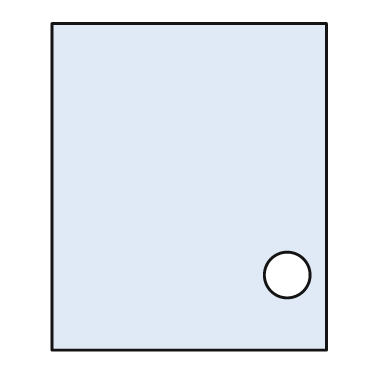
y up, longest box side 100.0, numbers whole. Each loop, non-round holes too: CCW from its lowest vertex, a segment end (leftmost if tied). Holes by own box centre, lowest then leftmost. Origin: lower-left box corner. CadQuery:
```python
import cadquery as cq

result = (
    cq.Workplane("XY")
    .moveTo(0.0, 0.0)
    .lineTo(84.0, 0.0)
    .lineTo(84.0, 100.0)
    .lineTo(0.0, 100.0)
    .close()
    .moveTo(72.0, 23.0)
    .circle(7.0)
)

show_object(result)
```